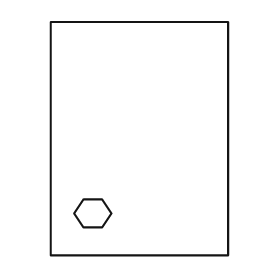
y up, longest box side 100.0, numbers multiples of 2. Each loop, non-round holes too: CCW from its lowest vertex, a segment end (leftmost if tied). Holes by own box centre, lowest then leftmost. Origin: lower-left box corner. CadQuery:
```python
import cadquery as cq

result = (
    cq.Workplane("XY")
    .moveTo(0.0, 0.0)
    .lineTo(76.0, 0.0)
    .lineTo(76.0, 100.0)
    .lineTo(0.0, 100.0)
    .close()
    .moveTo(14.0, 12.0)
    .lineTo(22.0, 12.0)
    .lineTo(26.0, 18.0)
    .lineTo(22.0, 24.0)
    .lineTo(14.0, 24.0)
    .lineTo(10.0, 18.0)
    .close()
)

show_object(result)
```